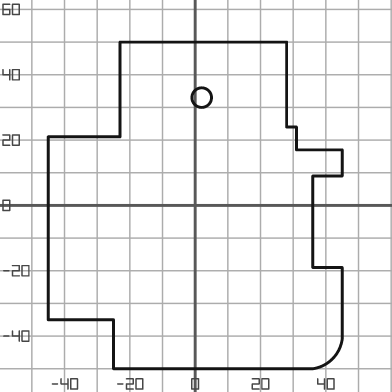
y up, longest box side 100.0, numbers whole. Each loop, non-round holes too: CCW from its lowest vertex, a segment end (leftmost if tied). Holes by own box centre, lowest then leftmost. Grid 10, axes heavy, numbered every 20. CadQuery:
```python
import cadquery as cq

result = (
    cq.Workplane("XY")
    .moveTo(-25.0, -50.0)
    .lineTo(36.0, -50.0)
    .threePointArc((42.0, -47.0), (45.0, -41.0))
    .lineTo(45.0, -19.0)
    .lineTo(36.0, -19.0)
    .lineTo(36.0, 9.0)
    .lineTo(45.0, 9.0)
    .lineTo(45.0, 17.0)
    .lineTo(31.0, 17.0)
    .lineTo(31.0, 24.0)
    .lineTo(28.0, 24.0)
    .lineTo(28.0, 50.0)
    .lineTo(-23.0, 50.0)
    .lineTo(-23.0, 21.0)
    .lineTo(-45.0, 21.0)
    .lineTo(-45.0, -35.0)
    .lineTo(-25.0, -35.0)
    .close()
    .moveTo(2.0, 33.0)
    .circle(3.0)
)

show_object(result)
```